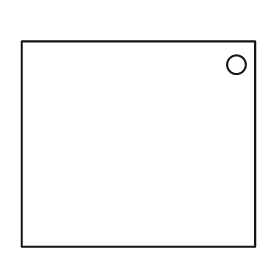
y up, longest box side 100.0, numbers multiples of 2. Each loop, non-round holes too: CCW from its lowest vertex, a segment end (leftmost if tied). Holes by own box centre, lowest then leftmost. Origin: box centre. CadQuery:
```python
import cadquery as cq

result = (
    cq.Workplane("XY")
    .moveTo(-50.0, -44.0)
    .lineTo(50.0, -44.0)
    .lineTo(50.0, 44.0)
    .lineTo(-50.0, 44.0)
    .close()
    .moveTo(42.0, 34.0)
    .circle(4.0)
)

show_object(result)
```